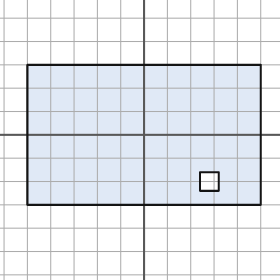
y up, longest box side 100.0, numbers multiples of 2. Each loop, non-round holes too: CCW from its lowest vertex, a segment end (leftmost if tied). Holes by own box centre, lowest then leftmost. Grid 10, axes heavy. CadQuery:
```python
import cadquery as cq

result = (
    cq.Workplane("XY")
    .moveTo(-50.0, -30.0)
    .lineTo(50.0, -30.0)
    .lineTo(50.0, 30.0)
    .lineTo(-50.0, 30.0)
    .close()
    .moveTo(24.0, -24.0)
    .lineTo(32.0, -24.0)
    .lineTo(32.0, -16.0)
    .lineTo(24.0, -16.0)
    .close()
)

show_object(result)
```